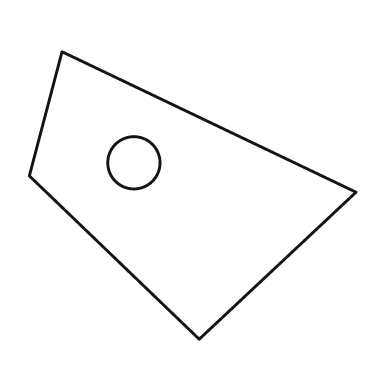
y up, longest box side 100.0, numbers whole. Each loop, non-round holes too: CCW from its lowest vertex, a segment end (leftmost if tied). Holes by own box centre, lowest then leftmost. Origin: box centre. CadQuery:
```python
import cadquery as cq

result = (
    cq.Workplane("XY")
    .moveTo(2.0, -44.0)
    .lineTo(50.0, 1.0)
    .lineTo(-40.0, 44.0)
    .lineTo(-50.0, 6.0)
    .close()
    .moveTo(-18.0, 10.0)
    .circle(8.0)
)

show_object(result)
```